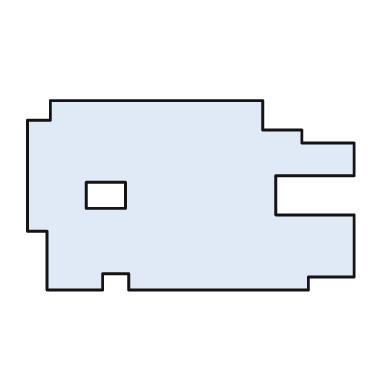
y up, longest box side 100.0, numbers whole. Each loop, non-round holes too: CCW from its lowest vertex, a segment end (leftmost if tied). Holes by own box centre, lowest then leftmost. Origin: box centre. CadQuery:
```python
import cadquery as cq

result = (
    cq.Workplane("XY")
    .moveTo(-44.0, -29.0)
    .lineTo(-27.0, -29.0)
    .lineTo(-27.0, -24.0)
    .lineTo(-19.0, -24.0)
    .lineTo(-19.0, -29.0)
    .lineTo(36.0, -29.0)
    .lineTo(36.0, -25.0)
    .lineTo(50.0, -25.0)
    .lineTo(50.0, -6.0)
    .lineTo(26.0, -6.0)
    .lineTo(26.0, 6.0)
    .lineTo(50.0, 6.0)
    .lineTo(50.0, 16.0)
    .lineTo(34.0, 16.0)
    .lineTo(34.0, 20.0)
    .lineTo(22.0, 20.0)
    .lineTo(22.0, 29.0)
    .lineTo(-43.0, 29.0)
    .lineTo(-43.0, 23.0)
    .lineTo(-50.0, 23.0)
    .lineTo(-50.0, -11.0)
    .lineTo(-44.0, -11.0)
    .close()
    .moveTo(-32.0, -4.0)
    .lineTo(-20.0, -4.0)
    .lineTo(-20.0, 4.0)
    .lineTo(-32.0, 4.0)
    .close()
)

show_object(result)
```